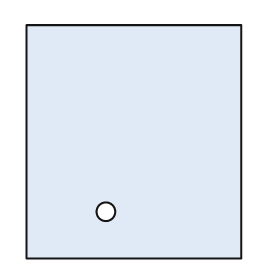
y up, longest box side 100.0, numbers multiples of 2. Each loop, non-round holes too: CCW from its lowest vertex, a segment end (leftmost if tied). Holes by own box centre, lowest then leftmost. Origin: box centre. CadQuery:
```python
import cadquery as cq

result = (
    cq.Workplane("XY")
    .moveTo(-46.0, -50.0)
    .lineTo(46.0, -50.0)
    .lineTo(46.0, 50.0)
    .lineTo(-46.0, 50.0)
    .close()
    .moveTo(-12.0, -30.0)
    .circle(4.0)
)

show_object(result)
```